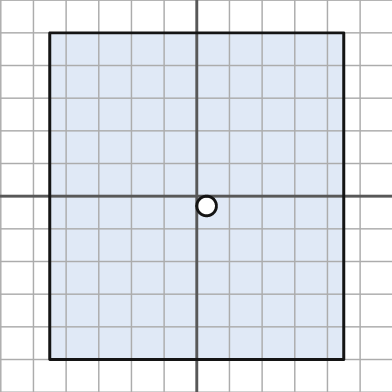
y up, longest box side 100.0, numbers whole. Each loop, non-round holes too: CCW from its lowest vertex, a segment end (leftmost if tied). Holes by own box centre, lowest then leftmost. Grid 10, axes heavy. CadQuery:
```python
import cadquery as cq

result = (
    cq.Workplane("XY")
    .moveTo(-45.0, -50.0)
    .lineTo(45.0, -50.0)
    .lineTo(45.0, 50.0)
    .lineTo(-45.0, 50.0)
    .close()
    .moveTo(3.0, -3.0)
    .circle(3.0)
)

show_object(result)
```